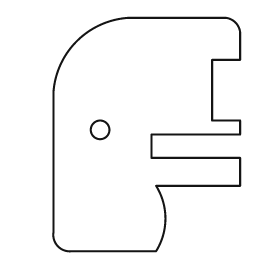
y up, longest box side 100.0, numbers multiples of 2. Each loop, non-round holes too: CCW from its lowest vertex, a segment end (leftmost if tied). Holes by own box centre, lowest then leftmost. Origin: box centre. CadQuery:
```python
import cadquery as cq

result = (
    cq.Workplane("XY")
    .moveTo(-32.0, -50.0)
    .lineTo(4.0, -50.0)
    .threePointArc((8.0, -36.0), (4.0, -22.0))
    .lineTo(40.0, -22.0)
    .lineTo(40.0, -10.0)
    .lineTo(2.0, -10.0)
    .lineTo(2.0, 0.0)
    .lineTo(40.0, 0.0)
    .lineTo(40.0, 6.0)
    .lineTo(28.0, 6.0)
    .lineTo(28.0, 32.0)
    .lineTo(40.0, 32.0)
    .lineTo(40.0, 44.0)
    .threePointArc((38.0, 48.0), (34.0, 50.0))
    .lineTo(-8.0, 50.0)
    .threePointArc((-30.0, 40.0), (-40.0, 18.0))
    .lineTo(-40.0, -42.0)
    .threePointArc((-38.0, -48.0), (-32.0, -50.0))
    .close()
    .moveTo(-20.0, 2.0)
    .circle(4.0)
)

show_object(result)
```